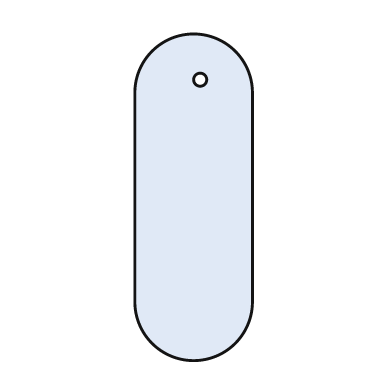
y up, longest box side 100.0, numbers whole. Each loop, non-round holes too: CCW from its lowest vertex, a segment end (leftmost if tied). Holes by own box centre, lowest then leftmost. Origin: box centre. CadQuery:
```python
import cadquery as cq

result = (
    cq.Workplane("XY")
    .moveTo(-18.0, -32.0)
    .threePointArc((0.0, -50.0), (18.0, -32.0))
    .lineTo(18.0, 32.0)
    .threePointArc((0.0, 50.0), (-18.0, 32.0))
    .close()
    .moveTo(2.0, 36.0)
    .circle(2.0)
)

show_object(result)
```